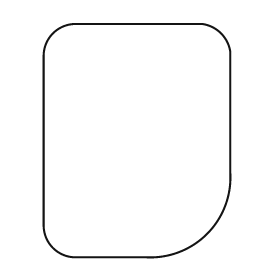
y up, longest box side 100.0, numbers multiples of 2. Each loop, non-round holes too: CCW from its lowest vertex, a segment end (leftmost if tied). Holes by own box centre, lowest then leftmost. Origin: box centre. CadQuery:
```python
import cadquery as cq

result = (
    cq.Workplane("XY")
    .moveTo(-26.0, -50.0)
    .lineTo(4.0, -50.0)
    .threePointArc((30.0, -40.0), (40.0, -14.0))
    .lineTo(40.0, 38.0)
    .threePointArc((36.0, 46.0), (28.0, 50.0))
    .lineTo(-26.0, 50.0)
    .threePointArc((-36.0, 46.0), (-40.0, 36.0))
    .lineTo(-40.0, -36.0)
    .threePointArc((-36.0, -46.0), (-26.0, -50.0))
    .close()
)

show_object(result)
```